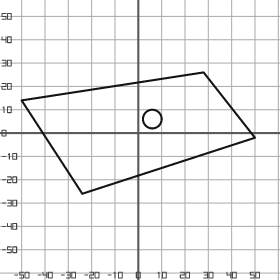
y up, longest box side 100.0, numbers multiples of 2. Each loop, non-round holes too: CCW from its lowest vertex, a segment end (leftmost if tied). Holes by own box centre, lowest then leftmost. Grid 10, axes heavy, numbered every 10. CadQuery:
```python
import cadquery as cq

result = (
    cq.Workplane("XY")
    .moveTo(-24.0, -26.0)
    .lineTo(50.0, -2.0)
    .lineTo(28.0, 26.0)
    .lineTo(-50.0, 14.0)
    .close()
    .moveTo(6.0, 6.0)
    .circle(4.0)
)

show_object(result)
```